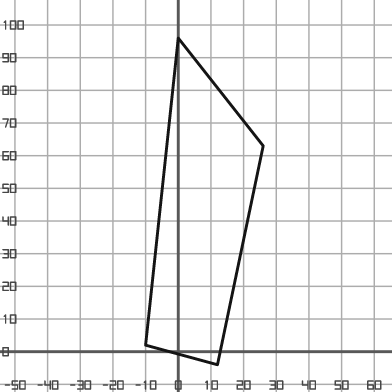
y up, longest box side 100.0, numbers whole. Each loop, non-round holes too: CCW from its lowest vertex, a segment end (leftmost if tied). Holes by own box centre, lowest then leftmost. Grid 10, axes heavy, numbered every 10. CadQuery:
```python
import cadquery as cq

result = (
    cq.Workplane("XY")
    .moveTo(12.0, -4.0)
    .lineTo(26.0, 63.0)
    .lineTo(0.0, 96.0)
    .lineTo(-10.0, 2.0)
    .close()
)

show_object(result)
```